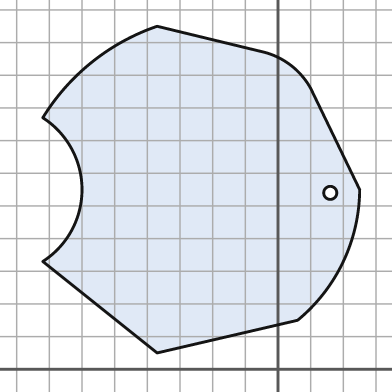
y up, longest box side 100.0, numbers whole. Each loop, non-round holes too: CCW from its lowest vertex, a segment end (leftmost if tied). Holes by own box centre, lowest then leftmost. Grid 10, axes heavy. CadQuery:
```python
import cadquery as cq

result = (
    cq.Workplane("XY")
    .moveTo(-37.0, 5.0)
    .lineTo(6.0, 15.0)
    .threePointArc((20.0, 33.0), (25.0, 55.0))
    .lineTo(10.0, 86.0)
    .threePointArc((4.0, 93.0), (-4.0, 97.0))
    .lineTo(-37.0, 105.0)
    .threePointArc((-57.0, 94.0), (-72.0, 77.0))
    .threePointArc((-60.0, 55.0), (-72.0, 33.0))
    .close()
    .moveTo(16.0, 54.0)
    .circle(2.0)
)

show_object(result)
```